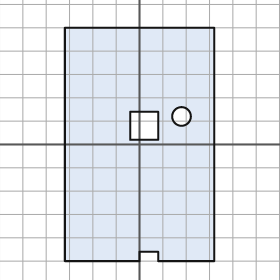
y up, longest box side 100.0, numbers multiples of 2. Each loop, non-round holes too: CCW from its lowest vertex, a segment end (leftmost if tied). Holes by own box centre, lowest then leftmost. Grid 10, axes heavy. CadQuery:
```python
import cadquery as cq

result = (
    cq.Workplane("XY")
    .moveTo(-32.0, -50.0)
    .lineTo(0.0, -50.0)
    .lineTo(0.0, -46.0)
    .lineTo(8.0, -46.0)
    .lineTo(8.0, -50.0)
    .lineTo(32.0, -50.0)
    .lineTo(32.0, 50.0)
    .lineTo(-32.0, 50.0)
    .close()
    .moveTo(-4.0, 2.0)
    .lineTo(8.0, 2.0)
    .lineTo(8.0, 14.0)
    .lineTo(-4.0, 14.0)
    .close()
    .moveTo(18.0, 12.0)
    .circle(4.0)
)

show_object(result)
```